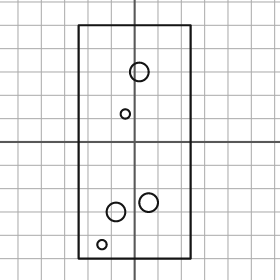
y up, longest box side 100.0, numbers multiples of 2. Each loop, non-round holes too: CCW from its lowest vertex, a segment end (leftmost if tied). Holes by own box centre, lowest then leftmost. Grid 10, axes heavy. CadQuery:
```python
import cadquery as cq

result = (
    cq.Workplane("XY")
    .moveTo(-24.0, -50.0)
    .lineTo(24.0, -50.0)
    .lineTo(24.0, 50.0)
    .lineTo(-24.0, 50.0)
    .close()
    .moveTo(-14.0, -44.0)
    .circle(2.0)
    .moveTo(-8.0, -30.0)
    .circle(4.0)
    .moveTo(6.0, -26.0)
    .circle(4.0)
    .moveTo(-4.0, 12.0)
    .circle(2.0)
    .moveTo(2.0, 30.0)
    .circle(4.0)
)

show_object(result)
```